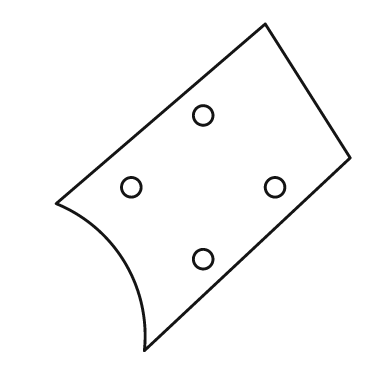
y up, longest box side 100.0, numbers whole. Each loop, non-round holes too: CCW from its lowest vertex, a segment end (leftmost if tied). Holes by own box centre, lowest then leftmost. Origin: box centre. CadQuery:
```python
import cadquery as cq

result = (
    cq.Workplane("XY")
    .moveTo(-18.0, -50.0)
    .lineTo(45.0, 9.0)
    .lineTo(19.0, 50.0)
    .lineTo(-45.0, -5.0)
    .threePointArc((-24.0, -23.0), (-18.0, -50.0))
    .close()
    .moveTo(0.0, -22.0)
    .circle(3.0)
    .moveTo(-22.0, 0.0)
    .circle(3.0)
    .moveTo(22.0, 0.0)
    .circle(3.0)
    .moveTo(0.0, 22.0)
    .circle(3.0)
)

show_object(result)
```